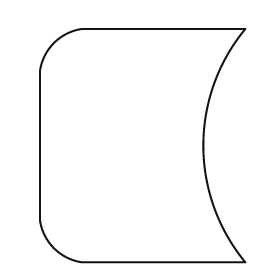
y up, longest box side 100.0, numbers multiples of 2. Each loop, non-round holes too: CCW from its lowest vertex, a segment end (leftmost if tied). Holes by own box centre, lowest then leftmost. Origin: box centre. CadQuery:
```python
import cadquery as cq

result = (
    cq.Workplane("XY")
    .moveTo(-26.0, -50.0)
    .lineTo(44.0, -50.0)
    .threePointArc((26.0, 0.0), (44.0, 50.0))
    .lineTo(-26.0, 50.0)
    .threePointArc((-38.0, 44.0), (-44.0, 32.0))
    .lineTo(-44.0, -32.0)
    .threePointArc((-38.0, -44.0), (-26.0, -50.0))
    .close()
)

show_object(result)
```